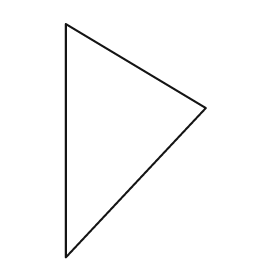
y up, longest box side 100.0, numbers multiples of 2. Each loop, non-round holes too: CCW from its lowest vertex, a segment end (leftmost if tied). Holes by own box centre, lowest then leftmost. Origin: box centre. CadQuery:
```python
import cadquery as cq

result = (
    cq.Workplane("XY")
    .moveTo(-30.0, -50.0)
    .lineTo(30.0, 14.0)
    .lineTo(-30.0, 50.0)
    .close()
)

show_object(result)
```